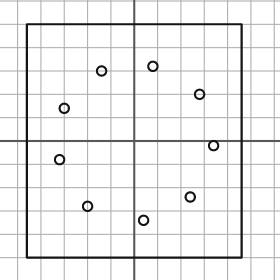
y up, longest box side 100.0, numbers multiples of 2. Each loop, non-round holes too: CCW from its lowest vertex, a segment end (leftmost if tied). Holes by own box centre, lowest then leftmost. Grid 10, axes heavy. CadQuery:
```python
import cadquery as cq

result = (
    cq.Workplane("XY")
    .moveTo(-46.0, -50.0)
    .lineTo(46.0, -50.0)
    .lineTo(46.0, 50.0)
    .lineTo(-46.0, 50.0)
    .close()
    .moveTo(4.0, -34.0)
    .circle(2.0)
    .moveTo(-20.0, -28.0)
    .circle(2.0)
    .moveTo(24.0, -24.0)
    .circle(2.0)
    .moveTo(-32.0, -8.0)
    .circle(2.0)
    .moveTo(34.0, -2.0)
    .circle(2.0)
    .moveTo(-30.0, 14.0)
    .circle(2.0)
    .moveTo(28.0, 20.0)
    .circle(2.0)
    .moveTo(-14.0, 30.0)
    .circle(2.0)
    .moveTo(8.0, 32.0)
    .circle(2.0)
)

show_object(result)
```